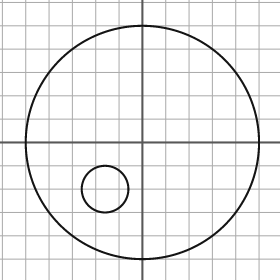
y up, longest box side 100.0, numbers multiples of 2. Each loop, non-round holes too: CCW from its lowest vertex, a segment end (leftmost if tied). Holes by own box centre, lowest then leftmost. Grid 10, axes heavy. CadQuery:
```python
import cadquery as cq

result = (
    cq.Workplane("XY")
    .moveTo(0.0, 0.0)
    .circle(50.0)
    .moveTo(-16.0, -20.0)
    .circle(10.0)
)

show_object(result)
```